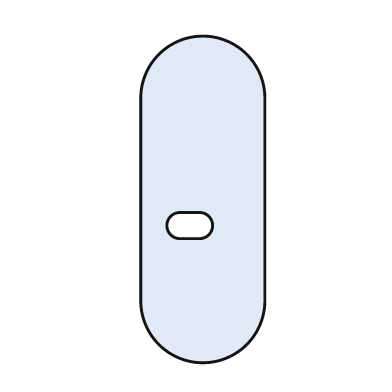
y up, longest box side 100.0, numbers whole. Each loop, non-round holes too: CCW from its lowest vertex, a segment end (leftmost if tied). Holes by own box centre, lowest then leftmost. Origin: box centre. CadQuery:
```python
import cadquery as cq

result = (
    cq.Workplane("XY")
    .moveTo(-19.0, -31.0)
    .threePointArc((0.0, -50.0), (19.0, -31.0))
    .lineTo(19.0, 31.0)
    .threePointArc((0.0, 50.0), (-19.0, 31.0))
    .close()
    .moveTo(-7.0, -12.0)
    .lineTo(-1.0, -12.0)
    .threePointArc((3.0, -8.0), (-1.0, -4.0))
    .lineTo(-7.0, -4.0)
    .threePointArc((-11.0, -8.0), (-7.0, -12.0))
    .close()
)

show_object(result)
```